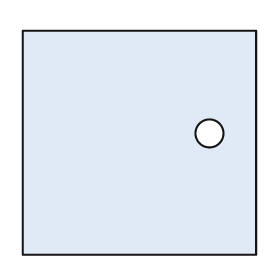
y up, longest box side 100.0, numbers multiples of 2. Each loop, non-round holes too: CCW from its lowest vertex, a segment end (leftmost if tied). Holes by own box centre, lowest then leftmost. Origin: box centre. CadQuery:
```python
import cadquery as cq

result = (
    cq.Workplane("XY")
    .moveTo(-50.0, -48.0)
    .lineTo(50.0, -48.0)
    .lineTo(50.0, 48.0)
    .lineTo(-50.0, 48.0)
    .close()
    .moveTo(30.0, 4.0)
    .circle(6.0)
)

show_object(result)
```